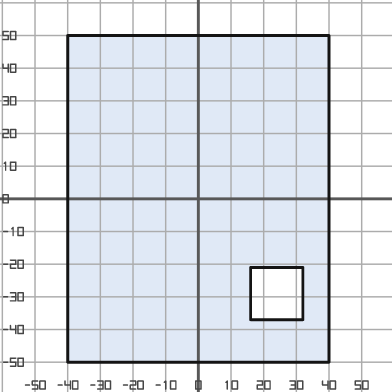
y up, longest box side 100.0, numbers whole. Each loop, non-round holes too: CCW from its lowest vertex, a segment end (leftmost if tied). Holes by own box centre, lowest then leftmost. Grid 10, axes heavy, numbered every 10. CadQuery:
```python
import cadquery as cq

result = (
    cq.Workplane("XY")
    .moveTo(-40.0, -50.0)
    .lineTo(40.0, -50.0)
    .lineTo(40.0, 50.0)
    .lineTo(-40.0, 50.0)
    .close()
    .moveTo(16.0, -37.0)
    .lineTo(32.0, -37.0)
    .lineTo(32.0, -21.0)
    .lineTo(16.0, -21.0)
    .close()
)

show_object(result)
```